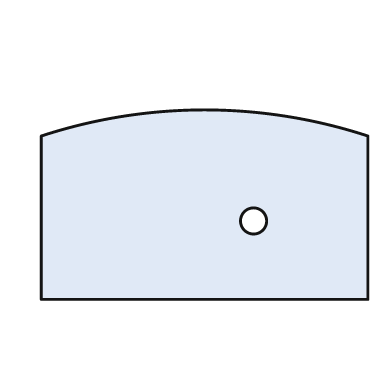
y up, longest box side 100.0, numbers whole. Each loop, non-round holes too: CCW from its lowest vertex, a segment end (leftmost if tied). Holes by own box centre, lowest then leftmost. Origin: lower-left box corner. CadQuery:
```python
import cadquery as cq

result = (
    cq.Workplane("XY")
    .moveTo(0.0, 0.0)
    .lineTo(100.0, 0.0)
    .lineTo(100.0, 50.0)
    .threePointArc((50.0, 58.0), (0.0, 50.0))
    .close()
    .moveTo(65.0, 24.0)
    .circle(4.0)
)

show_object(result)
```